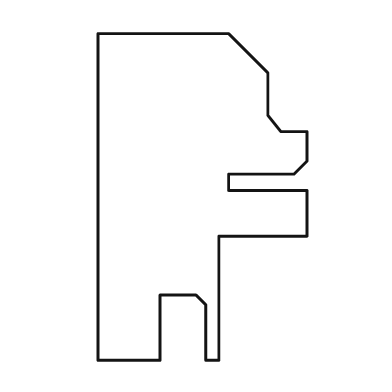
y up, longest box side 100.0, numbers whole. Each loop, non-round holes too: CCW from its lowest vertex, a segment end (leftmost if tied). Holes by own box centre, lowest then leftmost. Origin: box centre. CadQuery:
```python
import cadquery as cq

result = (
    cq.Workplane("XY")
    .moveTo(-32.0, -50.0)
    .lineTo(-13.0, -50.0)
    .lineTo(-13.0, -30.0)
    .lineTo(-2.0, -30.0)
    .lineTo(1.0, -33.0)
    .lineTo(1.0, -50.0)
    .lineTo(5.0, -50.0)
    .lineTo(5.0, -12.0)
    .lineTo(32.0, -12.0)
    .lineTo(32.0, 2.0)
    .lineTo(8.0, 2.0)
    .lineTo(8.0, 7.0)
    .lineTo(28.0, 7.0)
    .lineTo(32.0, 11.0)
    .lineTo(32.0, 20.0)
    .lineTo(24.0, 20.0)
    .lineTo(20.0, 25.0)
    .lineTo(20.0, 38.0)
    .lineTo(8.0, 50.0)
    .lineTo(-32.0, 50.0)
    .close()
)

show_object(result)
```